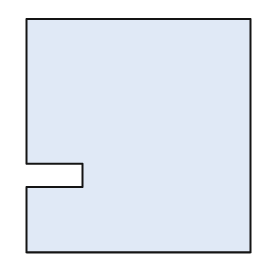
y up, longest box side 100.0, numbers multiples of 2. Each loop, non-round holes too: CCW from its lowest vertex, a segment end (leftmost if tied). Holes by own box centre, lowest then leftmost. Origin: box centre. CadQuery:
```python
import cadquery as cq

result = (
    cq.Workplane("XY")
    .moveTo(-48.0, -50.0)
    .lineTo(48.0, -50.0)
    .lineTo(48.0, 50.0)
    .lineTo(-48.0, 50.0)
    .lineTo(-48.0, -12.0)
    .lineTo(-24.0, -12.0)
    .lineTo(-24.0, -22.0)
    .lineTo(-48.0, -22.0)
    .close()
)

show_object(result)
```